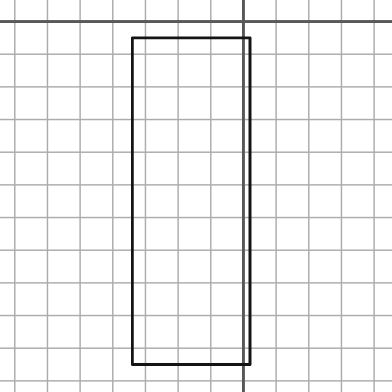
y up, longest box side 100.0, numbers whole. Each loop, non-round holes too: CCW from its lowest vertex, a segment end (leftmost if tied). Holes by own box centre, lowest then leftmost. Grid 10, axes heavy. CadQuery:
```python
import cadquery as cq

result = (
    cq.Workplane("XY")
    .moveTo(-34.0, -105.0)
    .lineTo(2.0, -105.0)
    .lineTo(2.0, -5.0)
    .lineTo(-34.0, -5.0)
    .close()
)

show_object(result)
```